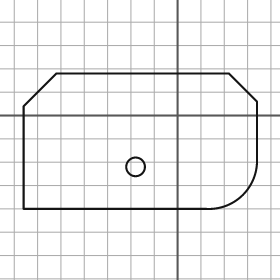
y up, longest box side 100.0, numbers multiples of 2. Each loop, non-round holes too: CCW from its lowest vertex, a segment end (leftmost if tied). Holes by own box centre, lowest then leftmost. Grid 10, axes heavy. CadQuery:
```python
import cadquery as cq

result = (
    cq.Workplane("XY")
    .moveTo(-66.0, -40.0)
    .lineTo(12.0, -40.0)
    .threePointArc((28.0, -34.0), (34.0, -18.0))
    .lineTo(34.0, 6.0)
    .lineTo(22.0, 18.0)
    .lineTo(-52.0, 18.0)
    .lineTo(-66.0, 4.0)
    .close()
    .moveTo(-18.0, -22.0)
    .circle(4.0)
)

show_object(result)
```